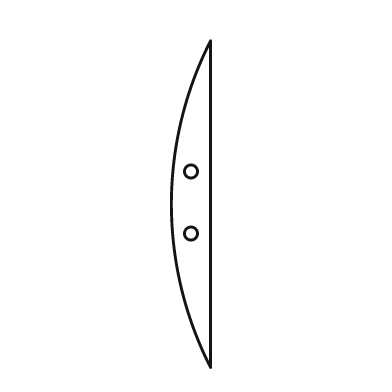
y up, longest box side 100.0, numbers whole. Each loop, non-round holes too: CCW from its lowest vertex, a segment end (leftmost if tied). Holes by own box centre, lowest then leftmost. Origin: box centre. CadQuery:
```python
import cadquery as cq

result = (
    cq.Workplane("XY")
    .moveTo(6.0, -50.0)
    .lineTo(6.0, 50.0)
    .threePointArc((-6.0, 0.0), (6.0, -50.0))
    .close()
    .moveTo(0.0, -9.0)
    .circle(2.0)
    .moveTo(0.0, 10.0)
    .circle(2.0)
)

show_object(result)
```